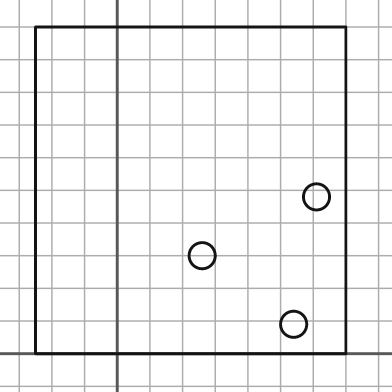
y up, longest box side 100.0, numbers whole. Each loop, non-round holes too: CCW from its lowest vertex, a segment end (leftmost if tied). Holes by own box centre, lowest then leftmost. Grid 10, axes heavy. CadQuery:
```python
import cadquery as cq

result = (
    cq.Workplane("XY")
    .moveTo(-25.0, 0.0)
    .lineTo(70.0, 0.0)
    .lineTo(70.0, 100.0)
    .lineTo(-25.0, 100.0)
    .close()
    .moveTo(54.0, 9.0)
    .circle(4.0)
    .moveTo(26.0, 30.0)
    .circle(4.0)
    .moveTo(61.0, 48.0)
    .circle(4.0)
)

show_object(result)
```